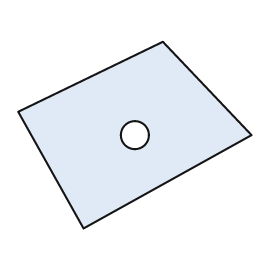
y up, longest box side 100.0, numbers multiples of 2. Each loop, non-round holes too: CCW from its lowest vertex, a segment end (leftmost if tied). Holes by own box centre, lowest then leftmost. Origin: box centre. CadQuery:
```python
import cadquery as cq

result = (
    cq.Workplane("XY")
    .moveTo(-22.0, -40.0)
    .lineTo(50.0, 0.0)
    .lineTo(12.0, 40.0)
    .lineTo(-50.0, 10.0)
    .close()
    .moveTo(0.0, 0.0)
    .circle(6.0)
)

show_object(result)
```